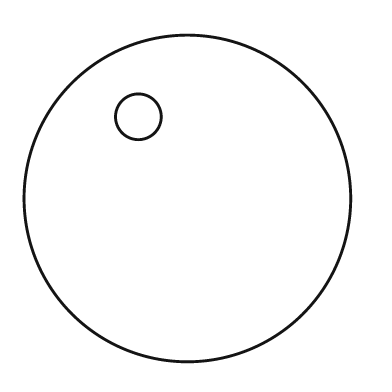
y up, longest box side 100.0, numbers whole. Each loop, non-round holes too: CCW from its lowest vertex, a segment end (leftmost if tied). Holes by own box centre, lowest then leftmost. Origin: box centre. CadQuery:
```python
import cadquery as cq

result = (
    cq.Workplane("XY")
    .moveTo(0.0, 0.0)
    .circle(50.0)
    .moveTo(-15.0, 25.0)
    .circle(7.0)
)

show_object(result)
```